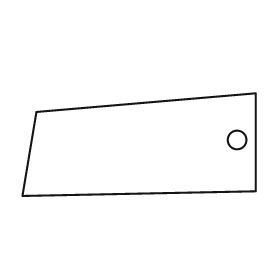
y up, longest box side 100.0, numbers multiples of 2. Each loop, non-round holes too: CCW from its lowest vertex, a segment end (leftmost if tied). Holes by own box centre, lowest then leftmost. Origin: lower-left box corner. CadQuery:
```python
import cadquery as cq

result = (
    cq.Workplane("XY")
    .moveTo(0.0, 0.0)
    .lineTo(100.0, 2.0)
    .lineTo(100.0, 44.0)
    .lineTo(6.0, 36.0)
    .close()
    .moveTo(92.0, 24.0)
    .circle(4.0)
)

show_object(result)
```